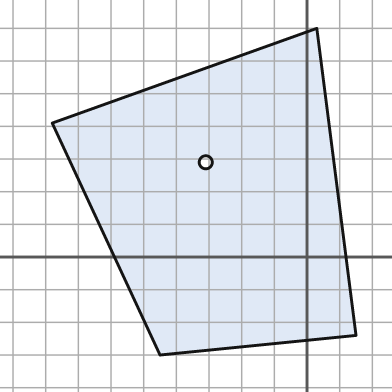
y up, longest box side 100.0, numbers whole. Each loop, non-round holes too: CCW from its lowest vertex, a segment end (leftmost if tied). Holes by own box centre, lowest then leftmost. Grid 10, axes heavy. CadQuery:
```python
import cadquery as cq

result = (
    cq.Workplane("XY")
    .moveTo(-45.0, -30.0)
    .lineTo(15.0, -24.0)
    .lineTo(3.0, 70.0)
    .lineTo(-78.0, 41.0)
    .close()
    .moveTo(-31.0, 29.0)
    .circle(2.0)
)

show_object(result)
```